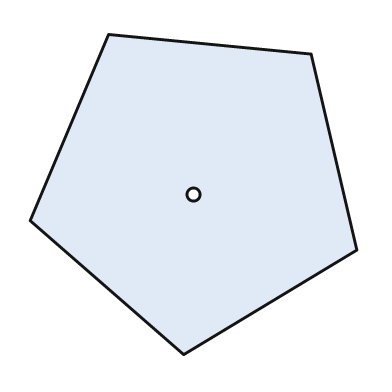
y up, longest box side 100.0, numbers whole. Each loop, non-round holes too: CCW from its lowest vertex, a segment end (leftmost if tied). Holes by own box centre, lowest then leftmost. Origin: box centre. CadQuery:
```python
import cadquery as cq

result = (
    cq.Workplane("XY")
    .moveTo(-3.0, -49.0)
    .lineTo(50.0, -17.0)
    .lineTo(36.0, 43.0)
    .lineTo(-26.0, 49.0)
    .lineTo(-50.0, -8.0)
    .close()
    .moveTo(0.0, 0.0)
    .circle(2.0)
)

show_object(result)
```